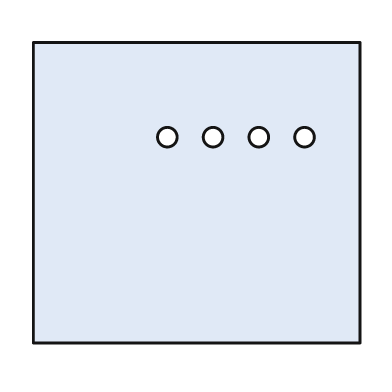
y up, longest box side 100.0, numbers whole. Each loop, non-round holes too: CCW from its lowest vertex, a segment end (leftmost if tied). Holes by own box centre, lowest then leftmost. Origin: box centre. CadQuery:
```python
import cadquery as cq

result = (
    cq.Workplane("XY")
    .moveTo(-50.0, -46.0)
    .lineTo(50.0, -46.0)
    .lineTo(50.0, 46.0)
    .lineTo(-50.0, 46.0)
    .close()
    .moveTo(-9.0, 17.0)
    .circle(3.0)
    .moveTo(5.0, 17.0)
    .circle(3.0)
    .moveTo(19.0, 17.0)
    .circle(3.0)
    .moveTo(33.0, 17.0)
    .circle(3.0)
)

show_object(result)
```